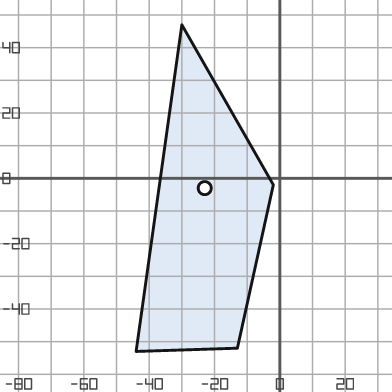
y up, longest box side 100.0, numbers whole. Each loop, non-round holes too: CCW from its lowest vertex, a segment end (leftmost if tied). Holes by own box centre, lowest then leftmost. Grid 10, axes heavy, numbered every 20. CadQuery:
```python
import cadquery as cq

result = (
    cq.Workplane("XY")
    .moveTo(-44.0, -53.0)
    .lineTo(-13.0, -52.0)
    .lineTo(-2.0, -2.0)
    .lineTo(-30.0, 47.0)
    .close()
    .moveTo(-23.0, -3.0)
    .circle(2.0)
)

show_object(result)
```